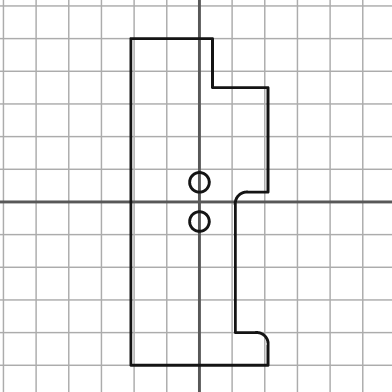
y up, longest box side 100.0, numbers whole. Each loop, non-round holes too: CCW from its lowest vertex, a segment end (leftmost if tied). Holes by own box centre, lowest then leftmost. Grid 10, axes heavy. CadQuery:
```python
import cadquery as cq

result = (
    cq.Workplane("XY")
    .moveTo(-21.0, -50.0)
    .lineTo(21.0, -50.0)
    .lineTo(21.0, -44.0)
    .threePointArc((20.0, -41.0), (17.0, -40.0))
    .lineTo(11.0, -40.0)
    .lineTo(11.0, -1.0)
    .threePointArc((12.0, 2.0), (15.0, 3.0))
    .lineTo(21.0, 3.0)
    .lineTo(21.0, 35.0)
    .lineTo(4.0, 35.0)
    .lineTo(4.0, 50.0)
    .lineTo(-21.0, 50.0)
    .close()
    .moveTo(0.0, -6.0)
    .circle(3.0)
    .moveTo(0.0, 6.0)
    .circle(3.0)
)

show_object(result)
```